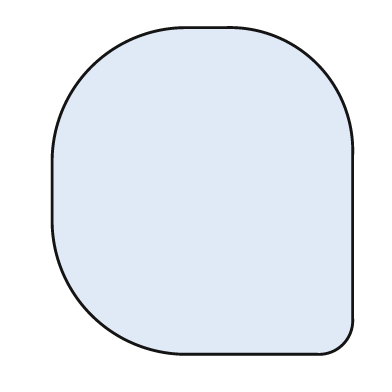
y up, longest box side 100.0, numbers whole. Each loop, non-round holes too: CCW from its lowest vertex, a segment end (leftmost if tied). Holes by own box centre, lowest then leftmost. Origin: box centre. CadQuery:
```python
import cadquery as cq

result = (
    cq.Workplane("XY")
    .moveTo(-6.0, -50.0)
    .lineTo(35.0, -50.0)
    .threePointArc((43.0, -47.0), (46.0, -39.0))
    .lineTo(46.0, 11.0)
    .threePointArc((35.0, 39.0), (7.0, 50.0))
    .lineTo(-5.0, 50.0)
    .threePointArc((-34.0, 38.0), (-46.0, 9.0))
    .lineTo(-46.0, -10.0)
    .threePointArc((-34.0, -38.0), (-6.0, -50.0))
    .close()
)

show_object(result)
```